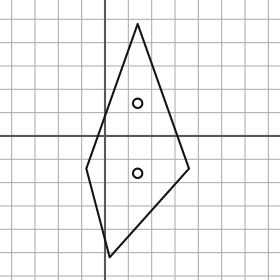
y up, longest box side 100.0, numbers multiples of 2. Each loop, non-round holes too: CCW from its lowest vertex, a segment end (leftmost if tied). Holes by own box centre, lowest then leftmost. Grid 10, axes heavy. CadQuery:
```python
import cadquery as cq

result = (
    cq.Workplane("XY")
    .moveTo(2.0, -52.0)
    .lineTo(36.0, -14.0)
    .lineTo(14.0, 48.0)
    .lineTo(-8.0, -14.0)
    .close()
    .moveTo(14.0, -16.0)
    .circle(2.0)
    .moveTo(14.0, 14.0)
    .circle(2.0)
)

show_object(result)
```